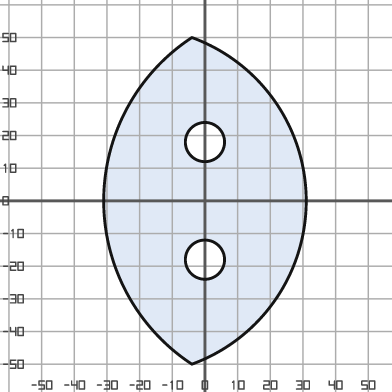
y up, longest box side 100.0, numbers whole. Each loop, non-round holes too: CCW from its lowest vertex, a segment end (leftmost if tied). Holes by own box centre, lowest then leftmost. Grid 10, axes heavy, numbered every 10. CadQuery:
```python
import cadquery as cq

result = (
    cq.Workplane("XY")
    .moveTo(-4.0, -50.0)
    .threePointArc((31.0, 0.0), (-4.0, 50.0))
    .threePointArc((-31.0, 0.0), (-4.0, -50.0))
    .close()
    .moveTo(0.0, -18.0)
    .circle(6.0)
    .moveTo(0.0, 18.0)
    .circle(6.0)
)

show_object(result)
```